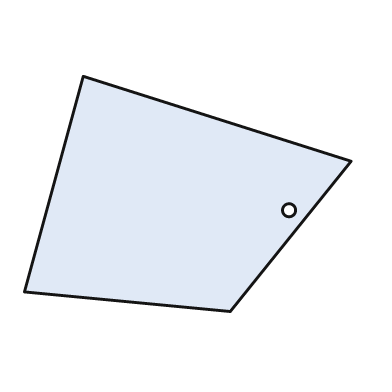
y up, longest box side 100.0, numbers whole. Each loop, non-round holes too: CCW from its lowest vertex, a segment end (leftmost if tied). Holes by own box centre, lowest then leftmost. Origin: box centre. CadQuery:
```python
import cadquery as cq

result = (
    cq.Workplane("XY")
    .moveTo(13.0, -36.0)
    .lineTo(50.0, 10.0)
    .lineTo(-32.0, 36.0)
    .lineTo(-50.0, -30.0)
    .close()
    .moveTo(31.0, -5.0)
    .circle(2.0)
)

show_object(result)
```